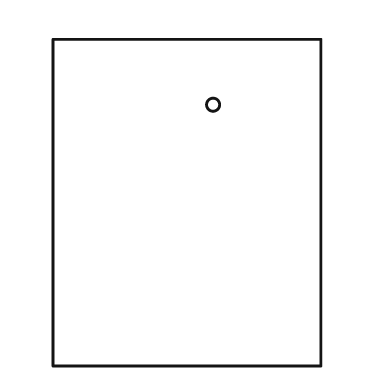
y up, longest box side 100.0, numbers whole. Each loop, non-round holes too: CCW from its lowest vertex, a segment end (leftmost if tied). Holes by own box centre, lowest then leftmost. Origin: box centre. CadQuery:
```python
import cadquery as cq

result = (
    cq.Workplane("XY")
    .moveTo(-41.0, -50.0)
    .lineTo(41.0, -50.0)
    .lineTo(41.0, 50.0)
    .lineTo(-41.0, 50.0)
    .close()
    .moveTo(8.0, 30.0)
    .circle(2.0)
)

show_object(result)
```